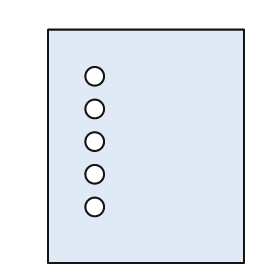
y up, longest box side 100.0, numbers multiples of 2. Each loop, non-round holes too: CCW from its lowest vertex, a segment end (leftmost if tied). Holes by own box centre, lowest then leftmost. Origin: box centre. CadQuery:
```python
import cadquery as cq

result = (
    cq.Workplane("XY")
    .moveTo(-42.0, -50.0)
    .lineTo(42.0, -50.0)
    .lineTo(42.0, 50.0)
    .lineTo(-42.0, 50.0)
    .close()
    .moveTo(-22.0, -26.0)
    .circle(4.0)
    .moveTo(-22.0, -12.0)
    .circle(4.0)
    .moveTo(-22.0, 2.0)
    .circle(4.0)
    .moveTo(-22.0, 16.0)
    .circle(4.0)
    .moveTo(-22.0, 30.0)
    .circle(4.0)
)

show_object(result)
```